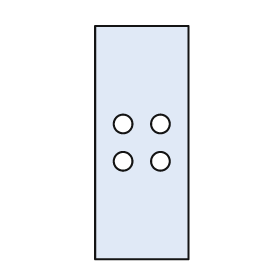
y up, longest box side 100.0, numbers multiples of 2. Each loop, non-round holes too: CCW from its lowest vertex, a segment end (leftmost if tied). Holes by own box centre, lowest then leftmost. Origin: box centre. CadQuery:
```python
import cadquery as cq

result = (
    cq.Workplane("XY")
    .moveTo(-20.0, -50.0)
    .lineTo(20.0, -50.0)
    .lineTo(20.0, 50.0)
    .lineTo(-20.0, 50.0)
    .close()
    .moveTo(-8.0, -8.0)
    .circle(4.0)
    .moveTo(8.0, -8.0)
    .circle(4.0)
    .moveTo(-8.0, 8.0)
    .circle(4.0)
    .moveTo(8.0, 8.0)
    .circle(4.0)
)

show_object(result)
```